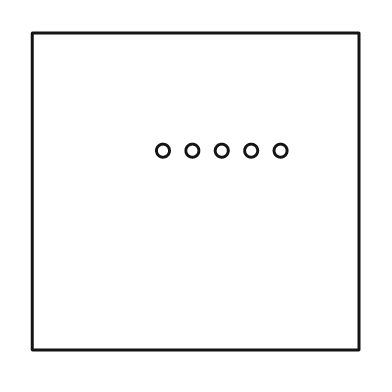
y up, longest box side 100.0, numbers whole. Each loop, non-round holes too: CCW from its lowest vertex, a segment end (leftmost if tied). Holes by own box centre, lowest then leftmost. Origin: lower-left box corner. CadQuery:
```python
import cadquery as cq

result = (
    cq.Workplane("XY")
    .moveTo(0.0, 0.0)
    .lineTo(100.0, 0.0)
    .lineTo(100.0, 97.0)
    .lineTo(0.0, 97.0)
    .close()
    .moveTo(40.0, 61.0)
    .circle(2.0)
    .moveTo(49.0, 61.0)
    .circle(2.0)
    .moveTo(58.0, 61.0)
    .circle(2.0)
    .moveTo(67.0, 61.0)
    .circle(2.0)
    .moveTo(76.0, 61.0)
    .circle(2.0)
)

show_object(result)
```